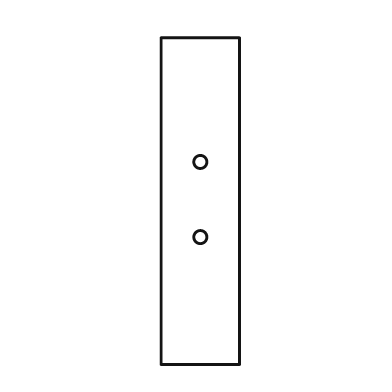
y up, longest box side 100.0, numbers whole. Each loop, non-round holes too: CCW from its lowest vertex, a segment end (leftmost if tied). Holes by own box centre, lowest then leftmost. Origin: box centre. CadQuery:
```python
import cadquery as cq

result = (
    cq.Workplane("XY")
    .moveTo(-12.0, -50.0)
    .lineTo(12.0, -50.0)
    .lineTo(12.0, 50.0)
    .lineTo(-12.0, 50.0)
    .close()
    .moveTo(0.0, -11.0)
    .circle(2.0)
    .moveTo(0.0, 12.0)
    .circle(2.0)
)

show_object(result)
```